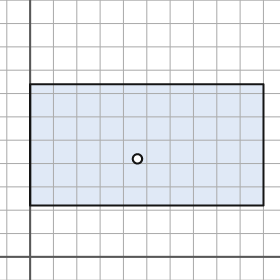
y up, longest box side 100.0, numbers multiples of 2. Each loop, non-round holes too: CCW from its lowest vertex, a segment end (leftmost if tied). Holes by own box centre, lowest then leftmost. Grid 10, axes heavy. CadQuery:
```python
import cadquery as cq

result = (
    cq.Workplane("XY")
    .moveTo(0.0, 22.0)
    .lineTo(100.0, 22.0)
    .lineTo(100.0, 74.0)
    .lineTo(0.0, 74.0)
    .close()
    .moveTo(46.0, 42.0)
    .circle(2.0)
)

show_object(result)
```